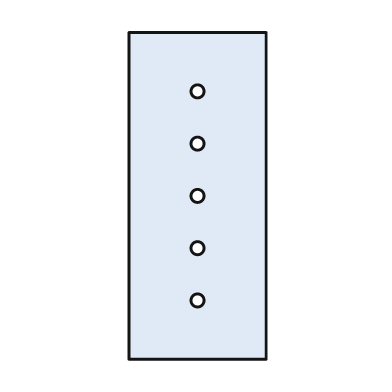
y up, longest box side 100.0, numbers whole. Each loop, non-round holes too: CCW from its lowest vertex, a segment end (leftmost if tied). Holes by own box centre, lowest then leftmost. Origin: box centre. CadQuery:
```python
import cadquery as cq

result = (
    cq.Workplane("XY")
    .moveTo(-21.0, -50.0)
    .lineTo(21.0, -50.0)
    .lineTo(21.0, 50.0)
    .lineTo(-21.0, 50.0)
    .close()
    .moveTo(0.0, -32.0)
    .circle(2.0)
    .moveTo(0.0, -16.0)
    .circle(2.0)
    .moveTo(0.0, 0.0)
    .circle(2.0)
    .moveTo(0.0, 16.0)
    .circle(2.0)
    .moveTo(0.0, 32.0)
    .circle(2.0)
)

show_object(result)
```